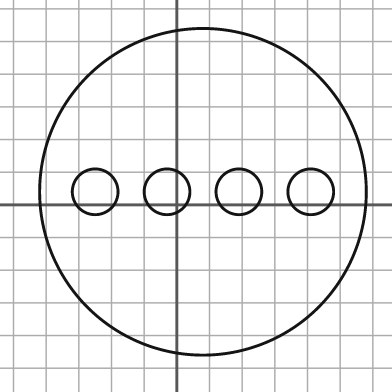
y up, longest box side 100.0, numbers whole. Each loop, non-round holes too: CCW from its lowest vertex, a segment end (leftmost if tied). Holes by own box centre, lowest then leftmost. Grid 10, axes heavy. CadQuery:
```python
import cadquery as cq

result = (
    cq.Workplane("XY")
    .moveTo(8.0, 4.0)
    .circle(50.0)
    .moveTo(-25.0, 4.0)
    .circle(7.0)
    .moveTo(-3.0, 4.0)
    .circle(7.0)
    .moveTo(19.0, 4.0)
    .circle(7.0)
    .moveTo(41.0, 4.0)
    .circle(7.0)
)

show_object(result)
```